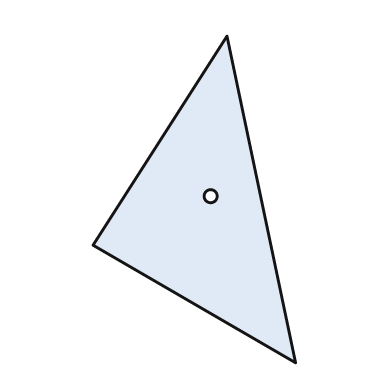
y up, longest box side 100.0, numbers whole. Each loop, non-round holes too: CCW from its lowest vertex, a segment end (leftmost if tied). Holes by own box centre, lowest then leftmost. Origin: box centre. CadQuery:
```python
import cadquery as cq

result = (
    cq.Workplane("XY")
    .moveTo(31.0, -50.0)
    .lineTo(10.0, 50.0)
    .lineTo(-31.0, -14.0)
    .close()
    .moveTo(5.0, 1.0)
    .circle(2.0)
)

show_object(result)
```